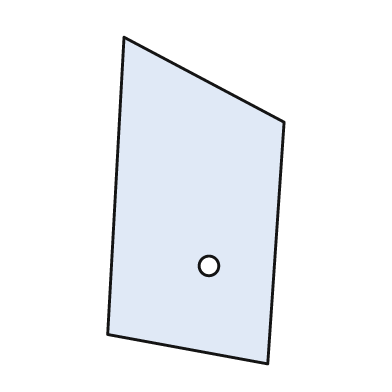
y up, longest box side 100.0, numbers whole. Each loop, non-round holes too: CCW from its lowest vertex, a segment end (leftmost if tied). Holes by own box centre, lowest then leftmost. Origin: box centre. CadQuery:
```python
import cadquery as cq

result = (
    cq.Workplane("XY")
    .moveTo(22.0, -50.0)
    .lineTo(27.0, 24.0)
    .lineTo(-22.0, 50.0)
    .lineTo(-27.0, -41.0)
    .close()
    .moveTo(4.0, -20.0)
    .circle(3.0)
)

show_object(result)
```